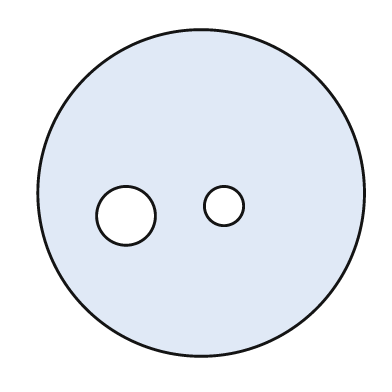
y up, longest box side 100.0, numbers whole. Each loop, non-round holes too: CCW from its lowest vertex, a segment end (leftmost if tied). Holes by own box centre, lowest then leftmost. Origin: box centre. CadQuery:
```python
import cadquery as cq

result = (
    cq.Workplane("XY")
    .moveTo(0.0, 0.0)
    .circle(50.0)
    .moveTo(-23.0, -7.0)
    .circle(9.0)
    .moveTo(7.0, -4.0)
    .circle(6.0)
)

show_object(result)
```